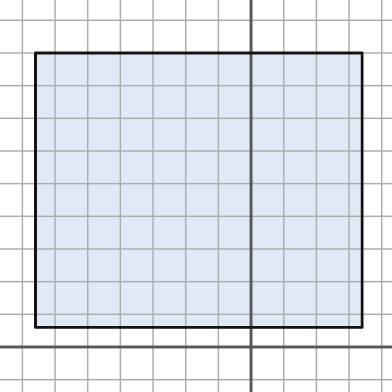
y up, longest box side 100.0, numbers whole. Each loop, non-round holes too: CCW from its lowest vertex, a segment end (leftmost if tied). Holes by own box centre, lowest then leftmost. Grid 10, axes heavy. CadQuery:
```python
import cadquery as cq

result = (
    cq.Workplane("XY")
    .moveTo(-66.0, 6.0)
    .lineTo(34.0, 6.0)
    .lineTo(34.0, 90.0)
    .lineTo(-66.0, 90.0)
    .close()
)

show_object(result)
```